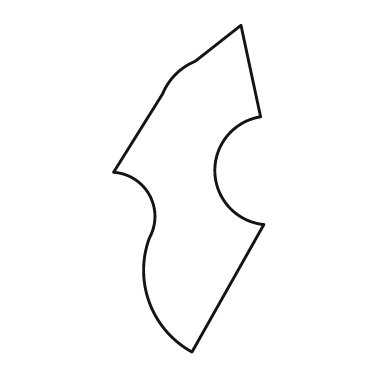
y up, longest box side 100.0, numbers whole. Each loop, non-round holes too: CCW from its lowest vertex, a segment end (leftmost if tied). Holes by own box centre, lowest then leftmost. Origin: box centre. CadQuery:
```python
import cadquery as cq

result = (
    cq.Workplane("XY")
    .moveTo(1.0, -50.0)
    .lineTo(23.0, -11.0)
    .threePointArc((8.0, 5.0), (22.0, 22.0))
    .lineTo(16.0, 50.0)
    .lineTo(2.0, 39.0)
    .threePointArc((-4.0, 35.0), (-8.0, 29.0))
    .lineTo(-23.0, 5.0)
    .threePointArc((-12.0, -2.0), (-12.0, -15.0))
    .threePointArc((-12.0, -35.0), (1.0, -50.0))
    .close()
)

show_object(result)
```